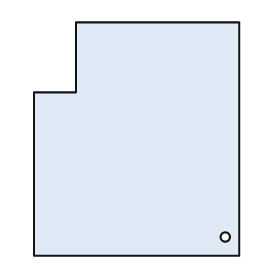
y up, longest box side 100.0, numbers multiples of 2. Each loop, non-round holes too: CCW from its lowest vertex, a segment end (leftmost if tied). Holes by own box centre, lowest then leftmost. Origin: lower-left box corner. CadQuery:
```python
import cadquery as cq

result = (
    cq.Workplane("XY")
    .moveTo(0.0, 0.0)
    .lineTo(88.0, 0.0)
    .lineTo(88.0, 100.0)
    .lineTo(18.0, 100.0)
    .lineTo(18.0, 70.0)
    .lineTo(0.0, 70.0)
    .close()
    .moveTo(82.0, 8.0)
    .circle(2.0)
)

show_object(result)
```